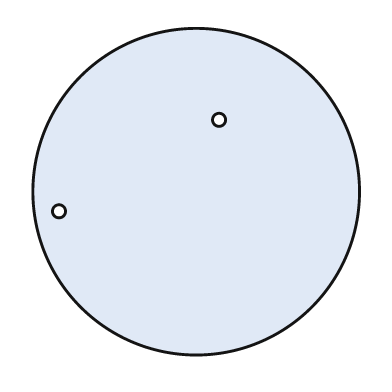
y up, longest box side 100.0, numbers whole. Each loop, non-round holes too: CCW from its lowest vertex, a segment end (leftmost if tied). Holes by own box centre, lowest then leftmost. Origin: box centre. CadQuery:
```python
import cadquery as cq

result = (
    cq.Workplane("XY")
    .moveTo(0.0, 0.0)
    .circle(50.0)
    .moveTo(-42.0, -6.0)
    .circle(2.0)
    .moveTo(7.0, 22.0)
    .circle(2.0)
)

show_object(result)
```